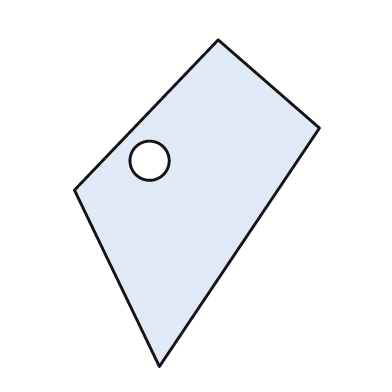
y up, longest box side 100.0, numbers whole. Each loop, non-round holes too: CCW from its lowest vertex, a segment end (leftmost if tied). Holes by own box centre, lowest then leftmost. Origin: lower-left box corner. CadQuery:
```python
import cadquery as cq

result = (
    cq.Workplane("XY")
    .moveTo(26.0, 0.0)
    .lineTo(75.0, 73.0)
    .lineTo(44.0, 100.0)
    .lineTo(0.0, 54.0)
    .close()
    .moveTo(23.0, 63.0)
    .circle(6.0)
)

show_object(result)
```